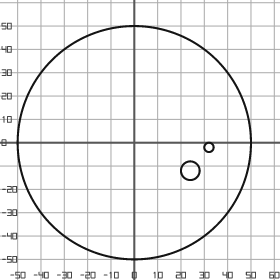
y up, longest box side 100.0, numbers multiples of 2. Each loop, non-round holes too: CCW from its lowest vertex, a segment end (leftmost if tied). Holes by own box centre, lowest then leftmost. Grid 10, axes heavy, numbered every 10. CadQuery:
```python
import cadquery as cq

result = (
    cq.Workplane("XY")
    .moveTo(0.0, 0.0)
    .circle(50.0)
    .moveTo(24.0, -12.0)
    .circle(4.0)
    .moveTo(32.0, -2.0)
    .circle(2.0)
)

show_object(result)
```